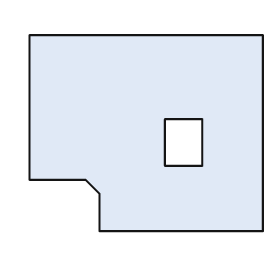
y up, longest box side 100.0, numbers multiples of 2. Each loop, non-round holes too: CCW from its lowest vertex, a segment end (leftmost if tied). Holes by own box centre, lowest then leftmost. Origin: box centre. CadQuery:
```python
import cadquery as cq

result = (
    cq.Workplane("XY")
    .moveTo(-20.0, -42.0)
    .lineTo(50.0, -42.0)
    .lineTo(50.0, 42.0)
    .lineTo(-50.0, 42.0)
    .lineTo(-50.0, -20.0)
    .lineTo(-26.0, -20.0)
    .lineTo(-20.0, -26.0)
    .close()
    .moveTo(8.0, -14.0)
    .lineTo(24.0, -14.0)
    .lineTo(24.0, 6.0)
    .lineTo(8.0, 6.0)
    .close()
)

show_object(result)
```